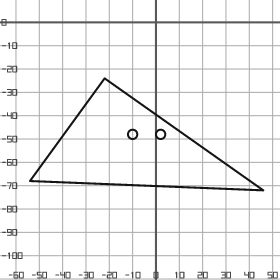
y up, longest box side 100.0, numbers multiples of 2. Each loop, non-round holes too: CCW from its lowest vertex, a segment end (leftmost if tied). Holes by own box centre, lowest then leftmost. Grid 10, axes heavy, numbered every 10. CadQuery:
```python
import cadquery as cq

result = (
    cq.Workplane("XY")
    .moveTo(46.0, -72.0)
    .lineTo(-22.0, -24.0)
    .lineTo(-54.0, -68.0)
    .close()
    .moveTo(-10.0, -48.0)
    .circle(2.0)
    .moveTo(2.0, -48.0)
    .circle(2.0)
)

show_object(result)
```